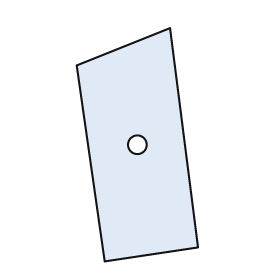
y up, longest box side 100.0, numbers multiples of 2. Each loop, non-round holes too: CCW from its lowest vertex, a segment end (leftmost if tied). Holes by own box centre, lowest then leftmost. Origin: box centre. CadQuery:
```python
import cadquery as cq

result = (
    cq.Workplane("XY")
    .moveTo(-14.0, -50.0)
    .lineTo(26.0, -44.0)
    .lineTo(14.0, 50.0)
    .lineTo(-26.0, 34.0)
    .close()
    .moveTo(0.0, 0.0)
    .circle(4.0)
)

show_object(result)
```